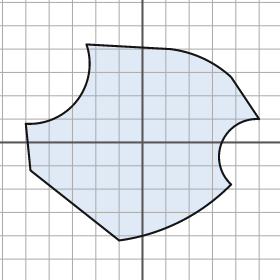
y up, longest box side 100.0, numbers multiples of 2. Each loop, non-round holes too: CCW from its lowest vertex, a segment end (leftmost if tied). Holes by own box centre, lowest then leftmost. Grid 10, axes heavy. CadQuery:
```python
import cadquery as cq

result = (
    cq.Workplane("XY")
    .moveTo(-10.0, -42.0)
    .threePointArc((16.0, -34.0), (38.0, -18.0))
    .threePointArc((34.0, 0.0), (50.0, 10.0))
    .lineTo(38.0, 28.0)
    .threePointArc((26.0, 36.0), (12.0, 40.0))
    .lineTo(-24.0, 42.0)
    .threePointArc((-28.0, 18.0), (-50.0, 8.0))
    .lineTo(-48.0, -12.0)
    .close()
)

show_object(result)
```